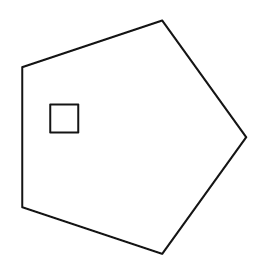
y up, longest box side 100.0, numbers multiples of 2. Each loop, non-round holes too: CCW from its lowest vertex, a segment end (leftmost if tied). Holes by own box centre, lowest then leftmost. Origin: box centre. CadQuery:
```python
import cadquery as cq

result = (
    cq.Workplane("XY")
    .moveTo(12.0, -50.0)
    .lineTo(48.0, 0.0)
    .lineTo(12.0, 50.0)
    .lineTo(-48.0, 30.0)
    .lineTo(-48.0, -30.0)
    .close()
    .moveTo(-36.0, 2.0)
    .lineTo(-24.0, 2.0)
    .lineTo(-24.0, 14.0)
    .lineTo(-36.0, 14.0)
    .close()
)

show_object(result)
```